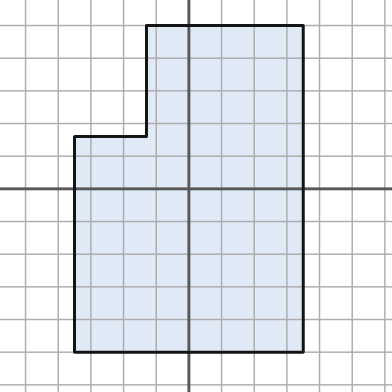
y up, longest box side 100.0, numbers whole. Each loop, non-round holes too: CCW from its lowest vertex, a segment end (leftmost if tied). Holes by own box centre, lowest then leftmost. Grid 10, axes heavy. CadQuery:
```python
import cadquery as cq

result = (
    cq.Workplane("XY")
    .moveTo(-35.0, -50.0)
    .lineTo(35.0, -50.0)
    .lineTo(35.0, 50.0)
    .lineTo(-13.0, 50.0)
    .lineTo(-13.0, 16.0)
    .lineTo(-35.0, 16.0)
    .close()
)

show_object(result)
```